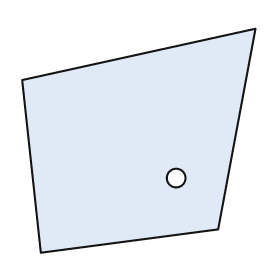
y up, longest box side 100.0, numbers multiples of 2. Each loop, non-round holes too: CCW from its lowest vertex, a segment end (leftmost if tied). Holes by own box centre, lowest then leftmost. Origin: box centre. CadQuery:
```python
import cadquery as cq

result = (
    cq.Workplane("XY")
    .moveTo(-42.0, -48.0)
    .lineTo(34.0, -38.0)
    .lineTo(50.0, 48.0)
    .lineTo(-50.0, 26.0)
    .close()
    .moveTo(16.0, -16.0)
    .circle(4.0)
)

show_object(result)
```